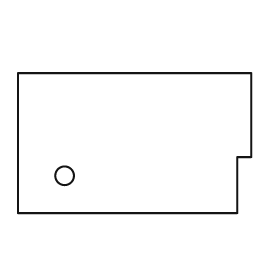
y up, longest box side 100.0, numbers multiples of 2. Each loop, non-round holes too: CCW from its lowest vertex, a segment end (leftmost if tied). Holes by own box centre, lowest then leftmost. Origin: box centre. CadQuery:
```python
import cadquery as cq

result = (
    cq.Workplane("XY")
    .moveTo(-50.0, -30.0)
    .lineTo(44.0, -30.0)
    .lineTo(44.0, -6.0)
    .lineTo(50.0, -6.0)
    .lineTo(50.0, 30.0)
    .lineTo(-50.0, 30.0)
    .close()
    .moveTo(-30.0, -14.0)
    .circle(4.0)
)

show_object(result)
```